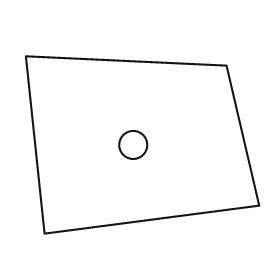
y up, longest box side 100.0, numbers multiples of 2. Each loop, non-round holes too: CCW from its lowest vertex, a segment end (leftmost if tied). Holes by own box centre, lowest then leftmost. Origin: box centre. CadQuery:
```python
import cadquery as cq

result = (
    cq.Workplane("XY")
    .moveTo(-42.0, -38.0)
    .lineTo(50.0, -26.0)
    .lineTo(36.0, 34.0)
    .lineTo(-50.0, 38.0)
    .close()
    .moveTo(-4.0, 0.0)
    .circle(6.0)
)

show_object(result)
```